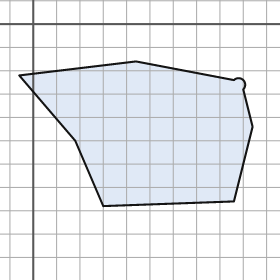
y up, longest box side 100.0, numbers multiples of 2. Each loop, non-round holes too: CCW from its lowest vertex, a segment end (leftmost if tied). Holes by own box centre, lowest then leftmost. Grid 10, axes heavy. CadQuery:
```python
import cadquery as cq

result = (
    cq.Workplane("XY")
    .moveTo(30.0, -78.0)
    .lineTo(86.0, -76.0)
    .lineTo(94.0, -44.0)
    .lineTo(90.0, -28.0)
    .threePointArc((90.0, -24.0), (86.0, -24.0))
    .lineTo(44.0, -16.0)
    .lineTo(-6.0, -22.0)
    .lineTo(18.0, -50.0)
    .close()
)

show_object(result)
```